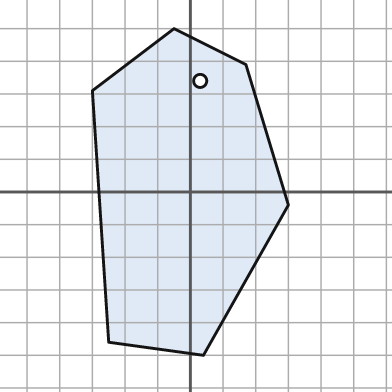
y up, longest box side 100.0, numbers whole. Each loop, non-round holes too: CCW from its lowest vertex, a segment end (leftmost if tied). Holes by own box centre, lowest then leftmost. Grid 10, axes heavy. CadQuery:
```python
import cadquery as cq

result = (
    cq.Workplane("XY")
    .moveTo(4.0, -50.0)
    .lineTo(30.0, -4.0)
    .lineTo(17.0, 39.0)
    .lineTo(-5.0, 50.0)
    .lineTo(-30.0, 31.0)
    .lineTo(-25.0, -46.0)
    .close()
    .moveTo(3.0, 34.0)
    .circle(2.0)
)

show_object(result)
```